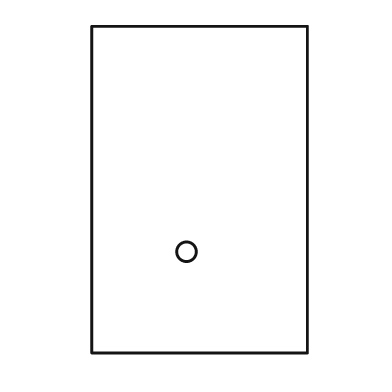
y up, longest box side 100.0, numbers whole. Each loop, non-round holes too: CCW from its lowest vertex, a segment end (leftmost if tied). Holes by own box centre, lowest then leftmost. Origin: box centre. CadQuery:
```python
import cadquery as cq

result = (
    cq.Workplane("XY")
    .moveTo(-33.0, -50.0)
    .lineTo(33.0, -50.0)
    .lineTo(33.0, 50.0)
    .lineTo(-33.0, 50.0)
    .close()
    .moveTo(-4.0, -19.0)
    .circle(3.0)
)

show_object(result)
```